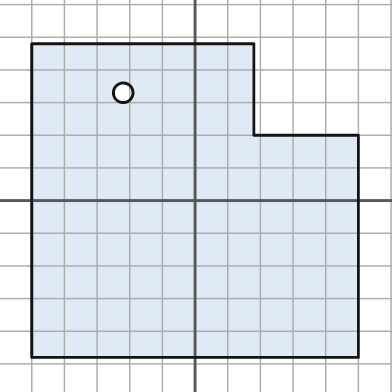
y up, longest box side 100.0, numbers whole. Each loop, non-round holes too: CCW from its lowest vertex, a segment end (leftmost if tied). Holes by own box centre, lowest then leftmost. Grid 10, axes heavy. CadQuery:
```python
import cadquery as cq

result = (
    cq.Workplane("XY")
    .moveTo(-50.0, -48.0)
    .lineTo(50.0, -48.0)
    .lineTo(50.0, 20.0)
    .lineTo(18.0, 20.0)
    .lineTo(18.0, 48.0)
    .lineTo(-50.0, 48.0)
    .close()
    .moveTo(-22.0, 33.0)
    .circle(3.0)
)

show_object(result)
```